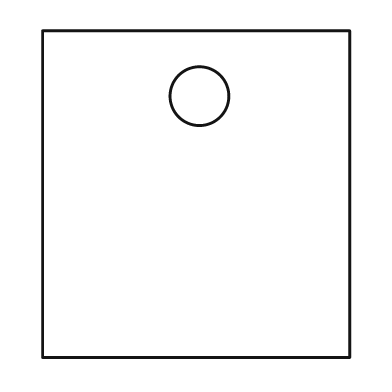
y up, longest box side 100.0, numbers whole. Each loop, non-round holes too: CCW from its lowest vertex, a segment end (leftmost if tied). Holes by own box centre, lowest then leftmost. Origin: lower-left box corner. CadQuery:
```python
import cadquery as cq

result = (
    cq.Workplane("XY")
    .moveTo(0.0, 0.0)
    .lineTo(94.0, 0.0)
    .lineTo(94.0, 100.0)
    .lineTo(0.0, 100.0)
    .close()
    .moveTo(48.0, 80.0)
    .circle(9.0)
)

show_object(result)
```